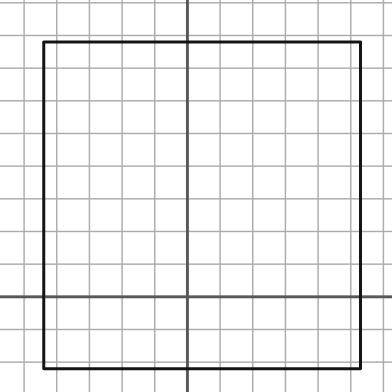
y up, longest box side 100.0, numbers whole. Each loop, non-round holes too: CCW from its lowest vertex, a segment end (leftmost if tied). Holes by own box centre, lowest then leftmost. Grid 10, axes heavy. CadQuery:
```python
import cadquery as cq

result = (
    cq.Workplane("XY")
    .moveTo(-44.0, -22.0)
    .lineTo(53.0, -22.0)
    .lineTo(53.0, 78.0)
    .lineTo(-44.0, 78.0)
    .close()
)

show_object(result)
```